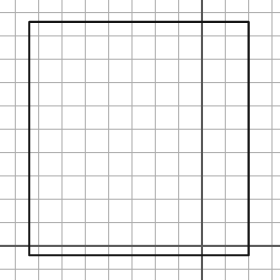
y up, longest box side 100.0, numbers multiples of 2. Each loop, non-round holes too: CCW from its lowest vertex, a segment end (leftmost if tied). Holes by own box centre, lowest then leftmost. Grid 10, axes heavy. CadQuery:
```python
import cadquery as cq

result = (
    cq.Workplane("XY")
    .moveTo(-74.0, -4.0)
    .lineTo(20.0, -4.0)
    .lineTo(20.0, 96.0)
    .lineTo(-74.0, 96.0)
    .close()
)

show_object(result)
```